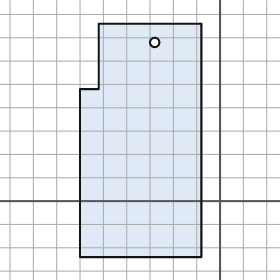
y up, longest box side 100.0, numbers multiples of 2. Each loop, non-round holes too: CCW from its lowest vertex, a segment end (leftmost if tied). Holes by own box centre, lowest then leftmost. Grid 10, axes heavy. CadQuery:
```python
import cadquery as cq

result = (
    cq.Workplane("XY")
    .moveTo(-60.0, -24.0)
    .lineTo(-8.0, -24.0)
    .lineTo(-8.0, 76.0)
    .lineTo(-52.0, 76.0)
    .lineTo(-52.0, 48.0)
    .lineTo(-60.0, 48.0)
    .close()
    .moveTo(-28.0, 68.0)
    .circle(2.0)
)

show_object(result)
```